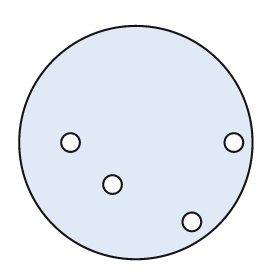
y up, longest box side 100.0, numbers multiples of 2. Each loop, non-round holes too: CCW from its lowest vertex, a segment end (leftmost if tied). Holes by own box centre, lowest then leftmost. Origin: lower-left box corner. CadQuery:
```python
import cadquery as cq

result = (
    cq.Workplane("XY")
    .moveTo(50.0, 50.0)
    .circle(50.0)
    .moveTo(74.0, 16.0)
    .circle(4.0)
    .moveTo(40.0, 32.0)
    .circle(4.0)
    .moveTo(22.0, 50.0)
    .circle(4.0)
    .moveTo(92.0, 50.0)
    .circle(4.0)
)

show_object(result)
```